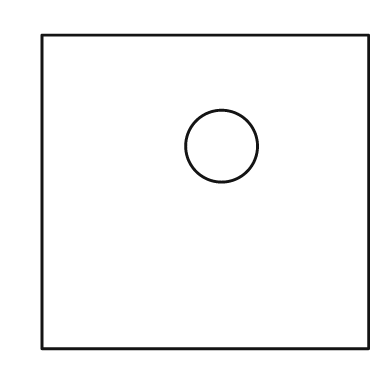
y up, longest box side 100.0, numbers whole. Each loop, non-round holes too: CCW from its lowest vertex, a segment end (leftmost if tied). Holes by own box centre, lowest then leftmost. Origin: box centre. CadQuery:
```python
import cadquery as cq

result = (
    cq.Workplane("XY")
    .moveTo(-50.0, -48.0)
    .lineTo(50.0, -48.0)
    .lineTo(50.0, 48.0)
    .lineTo(-50.0, 48.0)
    .close()
    .moveTo(5.0, 14.0)
    .circle(11.0)
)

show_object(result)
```